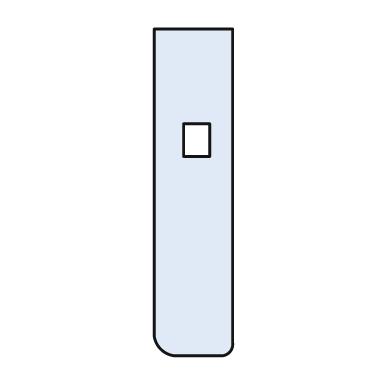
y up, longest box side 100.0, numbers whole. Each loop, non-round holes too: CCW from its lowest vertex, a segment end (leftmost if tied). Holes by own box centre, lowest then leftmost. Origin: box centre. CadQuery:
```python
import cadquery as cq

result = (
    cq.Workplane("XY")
    .moveTo(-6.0, -50.0)
    .lineTo(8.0, -50.0)
    .threePointArc((11.0, -49.0), (12.0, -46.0))
    .lineTo(12.0, 50.0)
    .lineTo(-12.0, 50.0)
    .lineTo(-12.0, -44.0)
    .threePointArc((-10.0, -48.0), (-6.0, -50.0))
    .close()
    .moveTo(-3.0, 11.0)
    .lineTo(5.0, 11.0)
    .lineTo(5.0, 21.0)
    .lineTo(-3.0, 21.0)
    .close()
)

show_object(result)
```